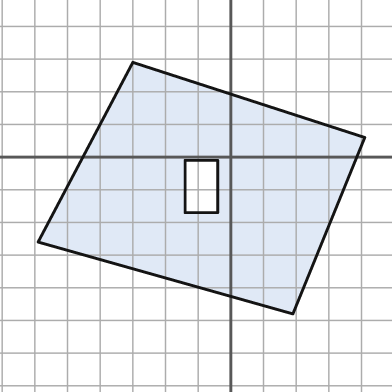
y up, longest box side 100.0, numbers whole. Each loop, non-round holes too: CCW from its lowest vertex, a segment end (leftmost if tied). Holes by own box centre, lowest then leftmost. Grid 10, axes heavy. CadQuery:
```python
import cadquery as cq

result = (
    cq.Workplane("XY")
    .moveTo(19.0, -48.0)
    .lineTo(41.0, 6.0)
    .lineTo(-30.0, 29.0)
    .lineTo(-59.0, -26.0)
    .close()
    .moveTo(-14.0, -17.0)
    .lineTo(-4.0, -17.0)
    .lineTo(-4.0, -1.0)
    .lineTo(-14.0, -1.0)
    .close()
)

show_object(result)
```